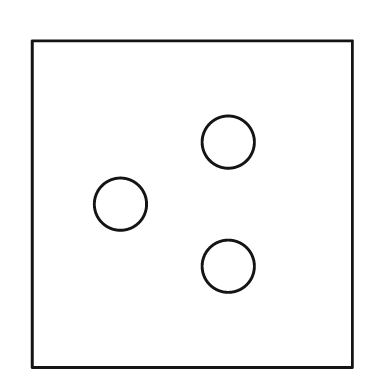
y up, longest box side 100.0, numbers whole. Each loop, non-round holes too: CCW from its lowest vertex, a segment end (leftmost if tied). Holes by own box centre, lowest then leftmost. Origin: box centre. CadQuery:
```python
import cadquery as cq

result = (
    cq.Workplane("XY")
    .moveTo(-49.0, -50.0)
    .lineTo(49.0, -50.0)
    .lineTo(49.0, 50.0)
    .lineTo(-49.0, 50.0)
    .close()
    .moveTo(11.0, -19.0)
    .circle(8.0)
    .moveTo(-22.0, 0.0)
    .circle(8.0)
    .moveTo(11.0, 19.0)
    .circle(8.0)
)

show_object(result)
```